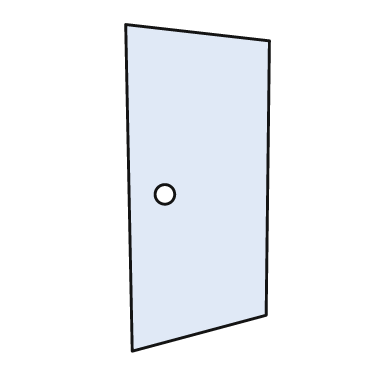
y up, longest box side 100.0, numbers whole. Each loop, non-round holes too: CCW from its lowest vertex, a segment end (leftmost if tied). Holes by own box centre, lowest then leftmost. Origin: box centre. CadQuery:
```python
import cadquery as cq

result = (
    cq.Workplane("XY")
    .moveTo(-20.0, -50.0)
    .lineTo(21.0, -39.0)
    .lineTo(22.0, 45.0)
    .lineTo(-22.0, 50.0)
    .close()
    .moveTo(-10.0, -2.0)
    .circle(3.0)
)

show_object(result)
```